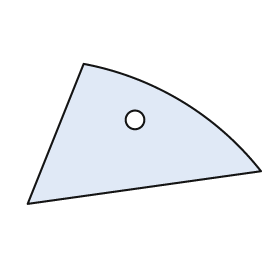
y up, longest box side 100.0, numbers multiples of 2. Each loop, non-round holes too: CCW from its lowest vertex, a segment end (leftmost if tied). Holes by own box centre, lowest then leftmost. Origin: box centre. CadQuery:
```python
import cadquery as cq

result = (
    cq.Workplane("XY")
    .moveTo(-50.0, -30.0)
    .lineTo(50.0, -16.0)
    .threePointArc((16.0, 14.0), (-26.0, 30.0))
    .close()
    .moveTo(-4.0, 6.0)
    .circle(4.0)
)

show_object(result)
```